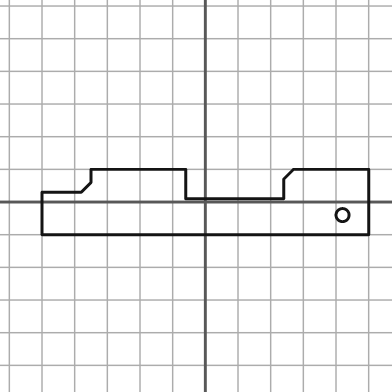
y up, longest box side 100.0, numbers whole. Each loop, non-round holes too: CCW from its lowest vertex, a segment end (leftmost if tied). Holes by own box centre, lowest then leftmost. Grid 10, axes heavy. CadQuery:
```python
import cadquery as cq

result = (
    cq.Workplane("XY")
    .moveTo(-50.0, -10.0)
    .lineTo(50.0, -10.0)
    .lineTo(50.0, 10.0)
    .lineTo(27.0, 10.0)
    .lineTo(24.0, 7.0)
    .lineTo(24.0, 1.0)
    .lineTo(-6.0, 1.0)
    .lineTo(-6.0, 10.0)
    .lineTo(-35.0, 10.0)
    .lineTo(-35.0, 6.0)
    .lineTo(-38.0, 3.0)
    .lineTo(-50.0, 3.0)
    .close()
    .moveTo(42.0, -4.0)
    .circle(2.0)
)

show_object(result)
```